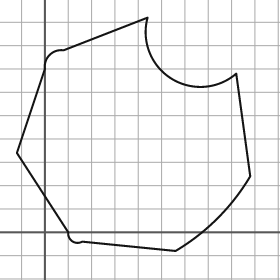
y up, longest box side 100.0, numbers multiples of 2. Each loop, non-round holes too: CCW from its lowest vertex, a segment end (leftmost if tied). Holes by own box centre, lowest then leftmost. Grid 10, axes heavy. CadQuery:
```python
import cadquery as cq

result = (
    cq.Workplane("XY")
    .moveTo(56.0, -8.0)
    .threePointArc((74.0, 6.0), (88.0, 24.0))
    .lineTo(82.0, 68.0)
    .threePointArc((54.0, 66.0), (44.0, 92.0))
    .lineTo(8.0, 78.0)
    .threePointArc((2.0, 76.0), (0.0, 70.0))
    .lineTo(-12.0, 34.0)
    .lineTo(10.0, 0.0)
    .threePointArc((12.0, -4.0), (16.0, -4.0))
    .close()
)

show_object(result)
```